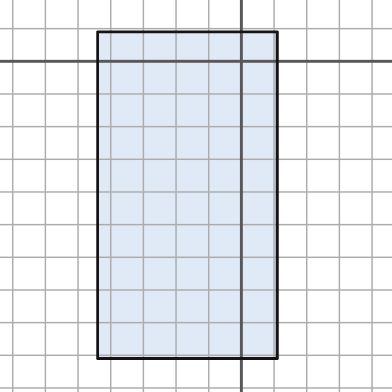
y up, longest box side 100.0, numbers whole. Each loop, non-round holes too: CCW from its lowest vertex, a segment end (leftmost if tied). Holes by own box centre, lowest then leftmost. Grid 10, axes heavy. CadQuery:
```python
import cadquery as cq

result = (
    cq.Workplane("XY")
    .moveTo(-44.0, -91.0)
    .lineTo(11.0, -91.0)
    .lineTo(11.0, 9.0)
    .lineTo(-44.0, 9.0)
    .close()
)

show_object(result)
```